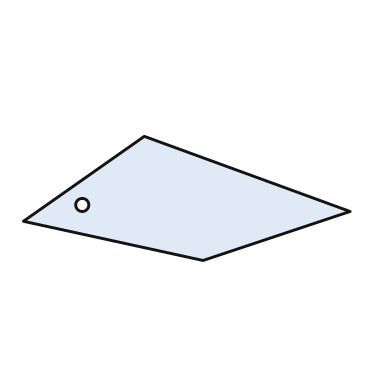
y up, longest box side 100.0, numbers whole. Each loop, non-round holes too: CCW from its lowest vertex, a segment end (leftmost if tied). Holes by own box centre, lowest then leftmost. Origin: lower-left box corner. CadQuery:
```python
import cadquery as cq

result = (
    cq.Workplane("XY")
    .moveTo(55.0, 0.0)
    .lineTo(100.0, 15.0)
    .lineTo(37.0, 38.0)
    .lineTo(0.0, 12.0)
    .close()
    .moveTo(18.0, 17.0)
    .circle(2.0)
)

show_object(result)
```